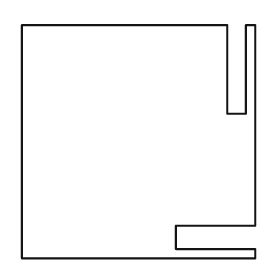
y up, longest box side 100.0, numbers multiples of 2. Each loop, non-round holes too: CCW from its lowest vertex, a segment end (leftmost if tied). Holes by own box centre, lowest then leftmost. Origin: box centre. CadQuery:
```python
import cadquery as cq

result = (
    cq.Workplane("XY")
    .moveTo(-50.0, -50.0)
    .lineTo(50.0, -50.0)
    .lineTo(50.0, -46.0)
    .lineTo(16.0, -46.0)
    .lineTo(16.0, -36.0)
    .lineTo(50.0, -36.0)
    .lineTo(50.0, 50.0)
    .lineTo(46.0, 50.0)
    .lineTo(46.0, 12.0)
    .lineTo(38.0, 12.0)
    .lineTo(38.0, 50.0)
    .lineTo(-50.0, 50.0)
    .close()
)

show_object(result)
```